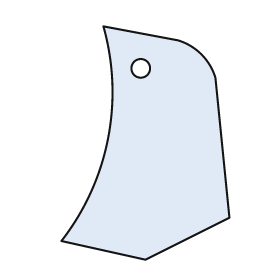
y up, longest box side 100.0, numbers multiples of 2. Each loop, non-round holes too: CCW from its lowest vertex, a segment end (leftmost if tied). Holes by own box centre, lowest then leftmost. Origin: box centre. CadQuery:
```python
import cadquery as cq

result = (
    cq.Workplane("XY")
    .moveTo(0.0, -50.0)
    .lineTo(36.0, -32.0)
    .lineTo(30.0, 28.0)
    .threePointArc((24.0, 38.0), (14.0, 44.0))
    .lineTo(-18.0, 50.0)
    .threePointArc((-16.0, 2.0), (-36.0, -42.0))
    .close()
    .moveTo(-2.0, 32.0)
    .circle(4.0)
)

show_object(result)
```